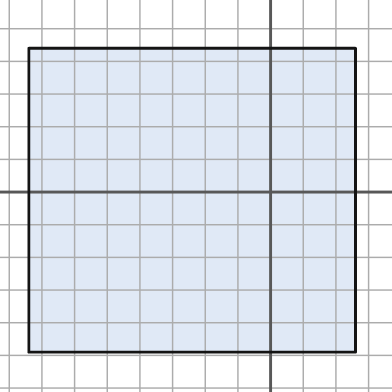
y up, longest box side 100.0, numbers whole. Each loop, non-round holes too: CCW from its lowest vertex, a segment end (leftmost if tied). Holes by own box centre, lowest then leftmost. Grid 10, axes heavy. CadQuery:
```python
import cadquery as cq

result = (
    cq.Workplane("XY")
    .moveTo(-74.0, -49.0)
    .lineTo(26.0, -49.0)
    .lineTo(26.0, 44.0)
    .lineTo(-74.0, 44.0)
    .close()
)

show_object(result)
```